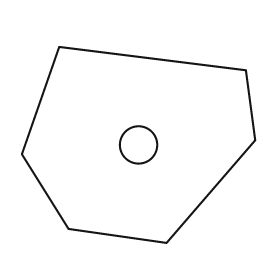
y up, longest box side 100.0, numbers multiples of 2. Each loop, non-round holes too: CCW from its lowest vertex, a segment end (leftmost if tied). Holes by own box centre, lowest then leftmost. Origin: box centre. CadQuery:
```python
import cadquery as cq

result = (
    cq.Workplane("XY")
    .moveTo(12.0, -42.0)
    .lineTo(50.0, 2.0)
    .lineTo(46.0, 32.0)
    .lineTo(-34.0, 42.0)
    .lineTo(-50.0, -4.0)
    .lineTo(-30.0, -36.0)
    .close()
    .moveTo(0.0, 0.0)
    .circle(8.0)
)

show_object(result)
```